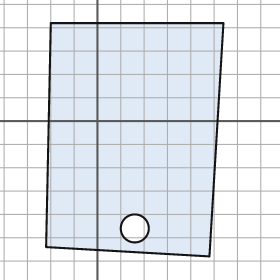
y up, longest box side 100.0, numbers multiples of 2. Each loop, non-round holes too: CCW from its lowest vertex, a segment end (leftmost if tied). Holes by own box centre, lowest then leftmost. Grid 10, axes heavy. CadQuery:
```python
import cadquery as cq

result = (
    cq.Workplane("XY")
    .moveTo(48.0, -58.0)
    .lineTo(54.0, 42.0)
    .lineTo(-20.0, 42.0)
    .lineTo(-22.0, -54.0)
    .close()
    .moveTo(16.0, -46.0)
    .circle(6.0)
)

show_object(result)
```